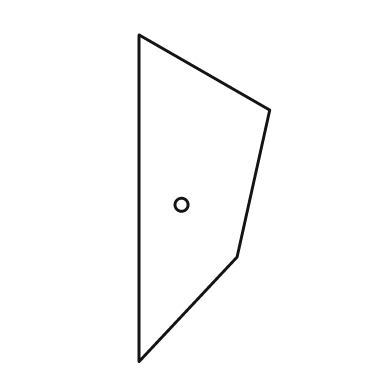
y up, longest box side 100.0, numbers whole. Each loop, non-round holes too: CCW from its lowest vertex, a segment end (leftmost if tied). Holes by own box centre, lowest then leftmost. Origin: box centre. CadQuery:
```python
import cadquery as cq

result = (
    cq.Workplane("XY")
    .moveTo(-20.0, -50.0)
    .lineTo(10.0, -18.0)
    .lineTo(20.0, 27.0)
    .lineTo(-20.0, 50.0)
    .close()
    .moveTo(-7.0, -2.0)
    .circle(2.0)
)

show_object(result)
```